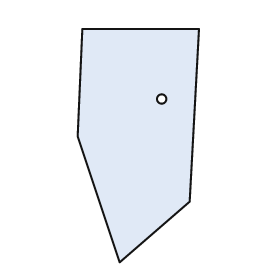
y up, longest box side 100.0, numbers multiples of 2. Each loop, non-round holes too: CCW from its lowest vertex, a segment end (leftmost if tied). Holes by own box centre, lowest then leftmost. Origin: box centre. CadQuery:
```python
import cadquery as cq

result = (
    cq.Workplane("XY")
    .moveTo(-8.0, -50.0)
    .lineTo(22.0, -24.0)
    .lineTo(26.0, 50.0)
    .lineTo(-24.0, 50.0)
    .lineTo(-26.0, 4.0)
    .close()
    .moveTo(10.0, 20.0)
    .circle(2.0)
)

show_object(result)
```